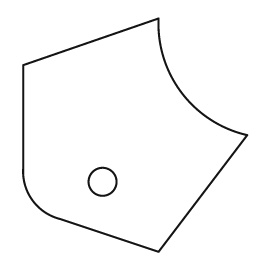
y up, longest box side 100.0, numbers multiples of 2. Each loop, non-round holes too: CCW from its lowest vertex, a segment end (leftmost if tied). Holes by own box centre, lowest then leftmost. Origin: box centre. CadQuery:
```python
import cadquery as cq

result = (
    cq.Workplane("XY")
    .moveTo(10.0, -50.0)
    .lineTo(48.0, 0.0)
    .threePointArc((20.0, 18.0), (10.0, 50.0))
    .lineTo(-48.0, 30.0)
    .lineTo(-48.0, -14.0)
    .threePointArc((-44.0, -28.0), (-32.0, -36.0))
    .close()
    .moveTo(-14.0, -20.0)
    .circle(6.0)
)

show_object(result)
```